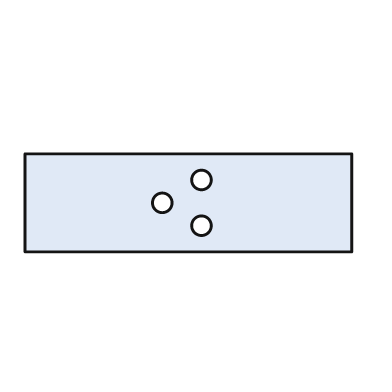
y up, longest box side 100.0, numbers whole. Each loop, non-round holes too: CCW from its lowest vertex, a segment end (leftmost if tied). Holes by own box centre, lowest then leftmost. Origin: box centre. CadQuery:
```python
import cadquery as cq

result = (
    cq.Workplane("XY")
    .moveTo(-50.0, -15.0)
    .lineTo(50.0, -15.0)
    .lineTo(50.0, 15.0)
    .lineTo(-50.0, 15.0)
    .close()
    .moveTo(4.0, -7.0)
    .circle(3.0)
    .moveTo(-8.0, 0.0)
    .circle(3.0)
    .moveTo(4.0, 7.0)
    .circle(3.0)
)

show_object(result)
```